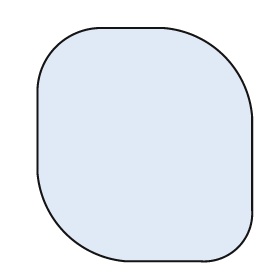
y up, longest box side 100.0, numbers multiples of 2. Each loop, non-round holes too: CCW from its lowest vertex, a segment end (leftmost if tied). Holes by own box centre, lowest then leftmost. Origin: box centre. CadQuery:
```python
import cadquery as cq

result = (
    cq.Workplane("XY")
    .moveTo(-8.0, -50.0)
    .lineTo(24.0, -50.0)
    .threePointArc((40.0, -44.0), (46.0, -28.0))
    .lineTo(46.0, 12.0)
    .threePointArc((34.0, 38.0), (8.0, 50.0))
    .lineTo(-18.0, 50.0)
    .threePointArc((-38.0, 42.0), (-46.0, 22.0))
    .lineTo(-46.0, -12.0)
    .threePointArc((-34.0, -38.0), (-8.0, -50.0))
    .close()
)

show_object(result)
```